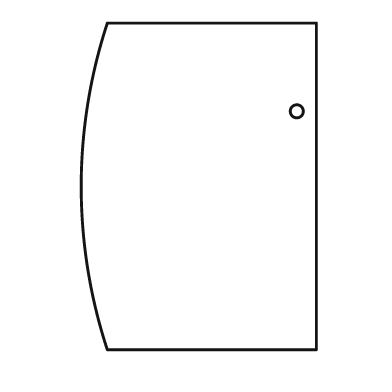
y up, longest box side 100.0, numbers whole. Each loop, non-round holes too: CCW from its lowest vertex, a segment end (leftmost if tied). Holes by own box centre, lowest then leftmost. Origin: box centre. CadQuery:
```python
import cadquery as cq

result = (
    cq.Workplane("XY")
    .moveTo(-28.0, -50.0)
    .lineTo(36.0, -50.0)
    .lineTo(36.0, 50.0)
    .lineTo(-28.0, 50.0)
    .threePointArc((-36.0, 0.0), (-28.0, -50.0))
    .close()
    .moveTo(30.0, 23.0)
    .circle(2.0)
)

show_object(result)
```